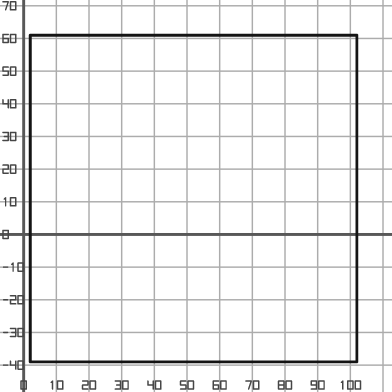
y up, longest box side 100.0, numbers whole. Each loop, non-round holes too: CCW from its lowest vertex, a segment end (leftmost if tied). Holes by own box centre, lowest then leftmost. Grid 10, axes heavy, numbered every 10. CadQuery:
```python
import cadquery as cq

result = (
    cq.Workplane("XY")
    .moveTo(2.0, -39.0)
    .lineTo(102.0, -39.0)
    .lineTo(102.0, 61.0)
    .lineTo(2.0, 61.0)
    .close()
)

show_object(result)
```